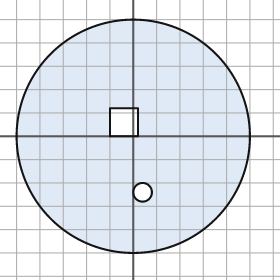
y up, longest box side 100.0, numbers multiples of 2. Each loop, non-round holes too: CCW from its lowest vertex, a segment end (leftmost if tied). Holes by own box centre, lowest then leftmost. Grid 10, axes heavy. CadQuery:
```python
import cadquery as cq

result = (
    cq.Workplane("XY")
    .moveTo(0.0, 0.0)
    .circle(50.0)
    .moveTo(4.0, -24.0)
    .circle(4.0)
    .moveTo(-10.0, 0.0)
    .lineTo(2.0, 0.0)
    .lineTo(2.0, 12.0)
    .lineTo(-10.0, 12.0)
    .close()
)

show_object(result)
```